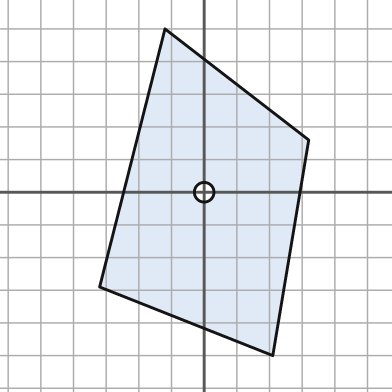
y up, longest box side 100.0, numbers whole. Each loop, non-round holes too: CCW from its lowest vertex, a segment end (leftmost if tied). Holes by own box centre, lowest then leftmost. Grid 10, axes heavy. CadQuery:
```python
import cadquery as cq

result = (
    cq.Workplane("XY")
    .moveTo(21.0, -50.0)
    .lineTo(32.0, 16.0)
    .lineTo(-12.0, 50.0)
    .lineTo(-32.0, -29.0)
    .close()
    .moveTo(0.0, 0.0)
    .circle(3.0)
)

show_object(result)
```